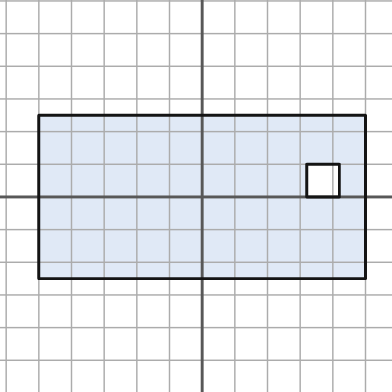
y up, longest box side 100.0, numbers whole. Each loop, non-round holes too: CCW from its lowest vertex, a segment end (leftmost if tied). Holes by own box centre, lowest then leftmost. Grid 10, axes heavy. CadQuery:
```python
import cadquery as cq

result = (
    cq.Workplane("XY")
    .moveTo(-50.0, -25.0)
    .lineTo(50.0, -25.0)
    .lineTo(50.0, 25.0)
    .lineTo(-50.0, 25.0)
    .close()
    .moveTo(32.0, 0.0)
    .lineTo(42.0, 0.0)
    .lineTo(42.0, 10.0)
    .lineTo(32.0, 10.0)
    .close()
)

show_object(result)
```